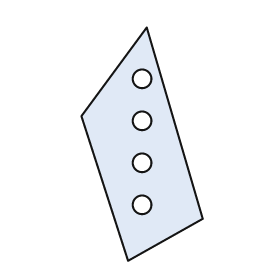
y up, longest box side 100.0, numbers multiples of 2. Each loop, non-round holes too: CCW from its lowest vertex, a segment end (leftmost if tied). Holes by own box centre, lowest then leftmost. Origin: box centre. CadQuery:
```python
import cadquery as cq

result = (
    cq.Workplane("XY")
    .moveTo(-6.0, -50.0)
    .lineTo(26.0, -32.0)
    .lineTo(2.0, 50.0)
    .lineTo(-26.0, 12.0)
    .close()
    .moveTo(0.0, -26.0)
    .circle(4.0)
    .moveTo(0.0, -8.0)
    .circle(4.0)
    .moveTo(0.0, 10.0)
    .circle(4.0)
    .moveTo(0.0, 28.0)
    .circle(4.0)
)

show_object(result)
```